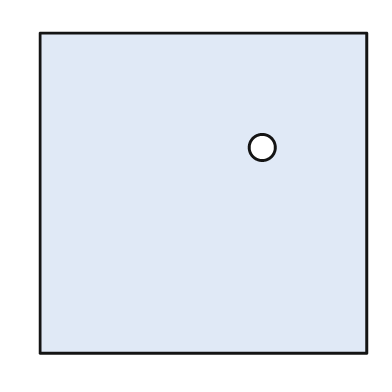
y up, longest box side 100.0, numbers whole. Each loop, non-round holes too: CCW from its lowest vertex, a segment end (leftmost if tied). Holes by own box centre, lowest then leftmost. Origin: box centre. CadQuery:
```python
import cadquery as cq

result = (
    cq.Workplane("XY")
    .moveTo(-50.0, -49.0)
    .lineTo(50.0, -49.0)
    .lineTo(50.0, 49.0)
    .lineTo(-50.0, 49.0)
    .close()
    .moveTo(18.0, 14.0)
    .circle(4.0)
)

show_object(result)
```